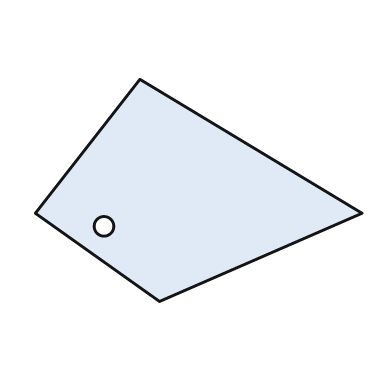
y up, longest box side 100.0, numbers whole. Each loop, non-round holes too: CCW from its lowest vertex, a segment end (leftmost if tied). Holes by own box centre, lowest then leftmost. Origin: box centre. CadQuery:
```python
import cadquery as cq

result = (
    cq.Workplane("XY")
    .moveTo(-12.0, -34.0)
    .lineTo(50.0, -7.0)
    .lineTo(-18.0, 34.0)
    .lineTo(-50.0, -7.0)
    .close()
    .moveTo(-29.0, -11.0)
    .circle(3.0)
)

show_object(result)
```